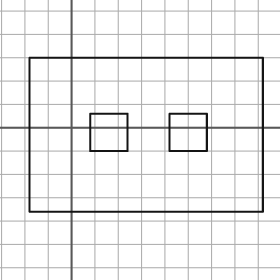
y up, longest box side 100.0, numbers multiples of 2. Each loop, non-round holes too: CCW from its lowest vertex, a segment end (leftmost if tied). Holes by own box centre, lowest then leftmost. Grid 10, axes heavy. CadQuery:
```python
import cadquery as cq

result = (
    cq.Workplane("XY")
    .moveTo(-18.0, -36.0)
    .lineTo(82.0, -36.0)
    .lineTo(82.0, 30.0)
    .lineTo(-18.0, 30.0)
    .close()
    .moveTo(8.0, -10.0)
    .lineTo(24.0, -10.0)
    .lineTo(24.0, 6.0)
    .lineTo(8.0, 6.0)
    .close()
    .moveTo(42.0, -10.0)
    .lineTo(58.0, -10.0)
    .lineTo(58.0, 6.0)
    .lineTo(42.0, 6.0)
    .close()
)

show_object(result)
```